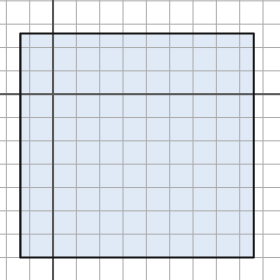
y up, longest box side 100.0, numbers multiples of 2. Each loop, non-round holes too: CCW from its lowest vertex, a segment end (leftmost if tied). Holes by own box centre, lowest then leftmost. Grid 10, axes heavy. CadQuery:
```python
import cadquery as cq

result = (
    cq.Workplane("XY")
    .moveTo(-14.0, -70.0)
    .lineTo(86.0, -70.0)
    .lineTo(86.0, 26.0)
    .lineTo(-14.0, 26.0)
    .close()
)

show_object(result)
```